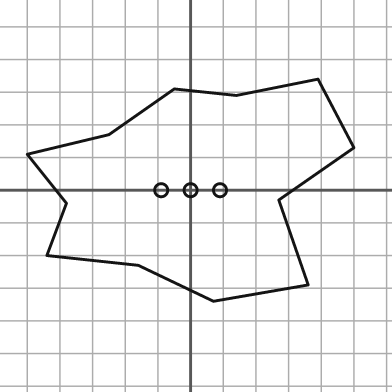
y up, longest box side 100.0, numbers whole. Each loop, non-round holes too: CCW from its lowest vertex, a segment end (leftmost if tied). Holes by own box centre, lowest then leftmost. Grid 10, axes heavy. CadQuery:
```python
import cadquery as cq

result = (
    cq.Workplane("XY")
    .moveTo(7.0, -34.0)
    .lineTo(36.0, -29.0)
    .lineTo(27.0, -3.0)
    .lineTo(50.0, 13.0)
    .lineTo(39.0, 34.0)
    .lineTo(14.0, 29.0)
    .lineTo(-5.0, 31.0)
    .lineTo(-25.0, 17.0)
    .lineTo(-50.0, 11.0)
    .lineTo(-38.0, -4.0)
    .lineTo(-44.0, -20.0)
    .lineTo(-16.0, -23.0)
    .close()
    .moveTo(-9.0, 0.0)
    .circle(2.0)
    .moveTo(0.0, 0.0)
    .circle(2.0)
    .moveTo(9.0, 0.0)
    .circle(2.0)
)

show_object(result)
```